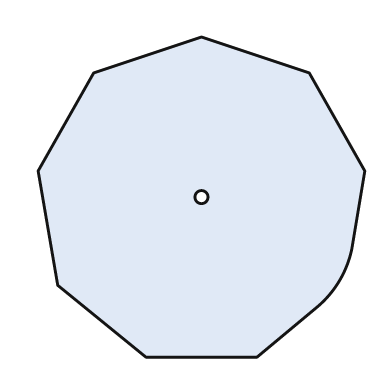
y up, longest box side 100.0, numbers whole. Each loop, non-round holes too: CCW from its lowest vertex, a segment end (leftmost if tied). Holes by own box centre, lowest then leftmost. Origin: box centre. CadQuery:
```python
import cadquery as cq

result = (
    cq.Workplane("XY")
    .moveTo(-17.0, -49.0)
    .lineTo(17.0, -49.0)
    .lineTo(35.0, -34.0)
    .threePointArc((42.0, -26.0), (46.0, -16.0))
    .lineTo(50.0, 8.0)
    .lineTo(33.0, 38.0)
    .lineTo(0.0, 49.0)
    .lineTo(-33.0, 38.0)
    .lineTo(-50.0, 8.0)
    .lineTo(-44.0, -27.0)
    .close()
    .moveTo(0.0, 0.0)
    .circle(2.0)
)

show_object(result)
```